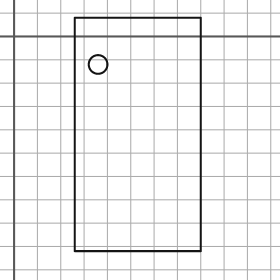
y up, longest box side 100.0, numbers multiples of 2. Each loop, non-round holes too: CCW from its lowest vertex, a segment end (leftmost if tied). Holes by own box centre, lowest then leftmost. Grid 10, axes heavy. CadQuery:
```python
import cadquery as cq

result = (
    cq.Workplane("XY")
    .moveTo(26.0, -92.0)
    .lineTo(80.0, -92.0)
    .lineTo(80.0, 8.0)
    .lineTo(26.0, 8.0)
    .close()
    .moveTo(36.0, -12.0)
    .circle(4.0)
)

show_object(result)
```